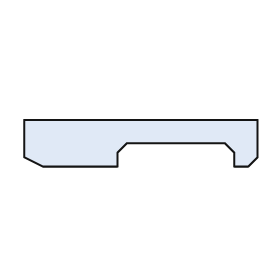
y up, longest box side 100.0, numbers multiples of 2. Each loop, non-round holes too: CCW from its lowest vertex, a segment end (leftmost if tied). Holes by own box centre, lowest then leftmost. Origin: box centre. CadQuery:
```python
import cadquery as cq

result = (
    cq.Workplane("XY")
    .moveTo(-42.0, -10.0)
    .lineTo(-10.0, -10.0)
    .lineTo(-10.0, -4.0)
    .lineTo(-6.0, 0.0)
    .lineTo(36.0, 0.0)
    .lineTo(40.0, -4.0)
    .lineTo(40.0, -10.0)
    .lineTo(46.0, -10.0)
    .lineTo(50.0, -6.0)
    .lineTo(50.0, 10.0)
    .lineTo(-50.0, 10.0)
    .lineTo(-50.0, -6.0)
    .close()
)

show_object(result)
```